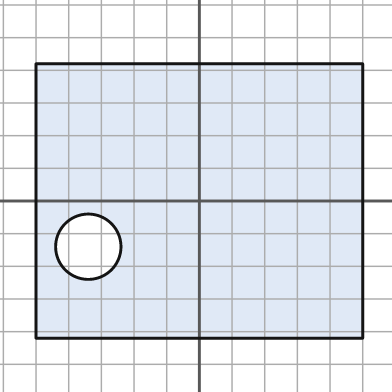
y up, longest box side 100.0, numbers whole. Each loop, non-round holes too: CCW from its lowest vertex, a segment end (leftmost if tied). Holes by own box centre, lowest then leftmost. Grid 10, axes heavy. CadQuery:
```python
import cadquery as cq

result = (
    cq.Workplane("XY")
    .moveTo(-50.0, -42.0)
    .lineTo(50.0, -42.0)
    .lineTo(50.0, 42.0)
    .lineTo(-50.0, 42.0)
    .close()
    .moveTo(-34.0, -14.0)
    .circle(10.0)
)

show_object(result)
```